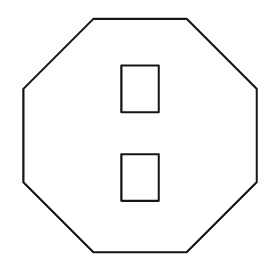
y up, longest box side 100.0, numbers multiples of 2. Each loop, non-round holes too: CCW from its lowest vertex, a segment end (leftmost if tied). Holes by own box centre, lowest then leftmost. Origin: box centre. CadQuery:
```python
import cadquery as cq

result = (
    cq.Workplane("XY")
    .moveTo(-20.0, -50.0)
    .lineTo(20.0, -50.0)
    .lineTo(50.0, -20.0)
    .lineTo(50.0, 20.0)
    .lineTo(20.0, 50.0)
    .lineTo(-20.0, 50.0)
    .lineTo(-50.0, 20.0)
    .lineTo(-50.0, -20.0)
    .close()
    .moveTo(-8.0, -28.0)
    .lineTo(8.0, -28.0)
    .lineTo(8.0, -8.0)
    .lineTo(-8.0, -8.0)
    .close()
    .moveTo(-8.0, 10.0)
    .lineTo(8.0, 10.0)
    .lineTo(8.0, 30.0)
    .lineTo(-8.0, 30.0)
    .close()
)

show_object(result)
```